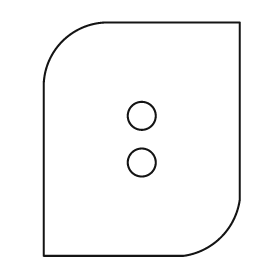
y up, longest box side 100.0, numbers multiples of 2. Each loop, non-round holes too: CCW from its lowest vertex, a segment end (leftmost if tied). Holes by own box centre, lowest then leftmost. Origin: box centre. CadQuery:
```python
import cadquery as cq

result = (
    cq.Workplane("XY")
    .moveTo(-42.0, -50.0)
    .lineTo(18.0, -50.0)
    .threePointArc((34.0, -42.0), (42.0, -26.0))
    .lineTo(42.0, 50.0)
    .lineTo(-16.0, 50.0)
    .threePointArc((-34.0, 42.0), (-42.0, 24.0))
    .close()
    .moveTo(0.0, -10.0)
    .circle(6.0)
    .moveTo(0.0, 10.0)
    .circle(6.0)
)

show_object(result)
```